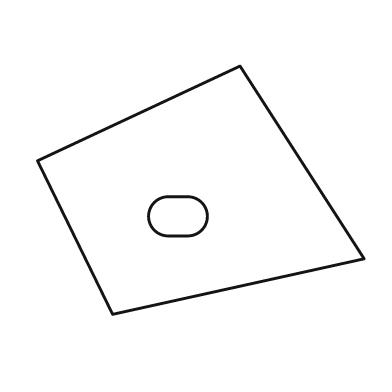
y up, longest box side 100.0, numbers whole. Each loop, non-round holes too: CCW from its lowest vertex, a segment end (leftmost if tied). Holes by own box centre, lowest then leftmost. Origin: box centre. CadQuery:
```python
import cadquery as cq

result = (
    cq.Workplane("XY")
    .moveTo(-27.0, -38.0)
    .lineTo(50.0, -21.0)
    .lineTo(12.0, 38.0)
    .lineTo(-50.0, 9.0)
    .close()
    .moveTo(-10.0, -14.0)
    .lineTo(-4.0, -14.0)
    .threePointArc((2.0, -8.0), (-4.0, -2.0))
    .lineTo(-10.0, -2.0)
    .threePointArc((-16.0, -8.0), (-10.0, -14.0))
    .close()
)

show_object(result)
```